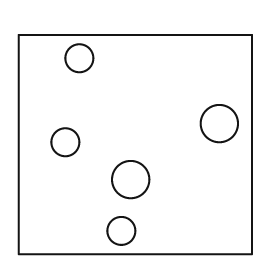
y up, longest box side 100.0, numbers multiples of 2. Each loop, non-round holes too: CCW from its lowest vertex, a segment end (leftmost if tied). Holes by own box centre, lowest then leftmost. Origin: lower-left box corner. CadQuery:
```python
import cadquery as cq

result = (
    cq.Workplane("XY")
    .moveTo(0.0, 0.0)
    .lineTo(100.0, 0.0)
    .lineTo(100.0, 94.0)
    .lineTo(0.0, 94.0)
    .close()
    .moveTo(44.0, 10.0)
    .circle(6.0)
    .moveTo(48.0, 32.0)
    .circle(8.0)
    .moveTo(20.0, 48.0)
    .circle(6.0)
    .moveTo(86.0, 56.0)
    .circle(8.0)
    .moveTo(26.0, 84.0)
    .circle(6.0)
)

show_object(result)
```